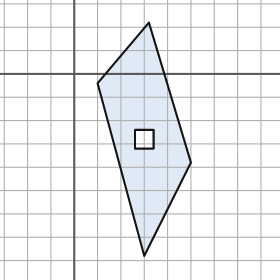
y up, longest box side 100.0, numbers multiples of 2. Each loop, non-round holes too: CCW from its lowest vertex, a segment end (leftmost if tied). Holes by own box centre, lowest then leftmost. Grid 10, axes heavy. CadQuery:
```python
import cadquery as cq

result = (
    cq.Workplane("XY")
    .moveTo(30.0, -78.0)
    .lineTo(50.0, -38.0)
    .lineTo(32.0, 22.0)
    .lineTo(10.0, -4.0)
    .close()
    .moveTo(26.0, -32.0)
    .lineTo(34.0, -32.0)
    .lineTo(34.0, -24.0)
    .lineTo(26.0, -24.0)
    .close()
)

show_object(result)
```